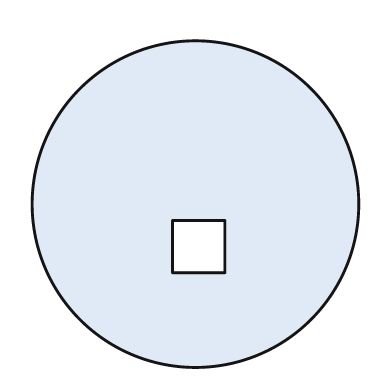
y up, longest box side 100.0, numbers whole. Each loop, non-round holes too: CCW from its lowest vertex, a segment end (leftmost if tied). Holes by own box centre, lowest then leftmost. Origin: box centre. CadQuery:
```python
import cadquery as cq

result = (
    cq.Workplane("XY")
    .moveTo(0.0, 0.0)
    .circle(50.0)
    .moveTo(-7.0, -21.0)
    .lineTo(9.0, -21.0)
    .lineTo(9.0, -5.0)
    .lineTo(-7.0, -5.0)
    .close()
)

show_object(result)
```